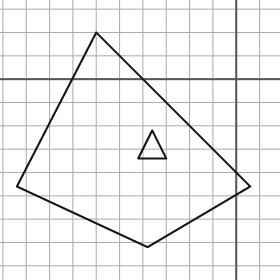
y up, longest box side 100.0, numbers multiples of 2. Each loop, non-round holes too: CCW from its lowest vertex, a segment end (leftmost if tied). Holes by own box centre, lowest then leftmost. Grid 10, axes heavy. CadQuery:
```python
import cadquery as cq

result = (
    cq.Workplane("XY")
    .moveTo(-38.0, -72.0)
    .lineTo(6.0, -46.0)
    .lineTo(-60.0, 20.0)
    .lineTo(-94.0, -46.0)
    .close()
    .moveTo(-42.0, -34.0)
    .lineTo(-30.0, -34.0)
    .lineTo(-36.0, -22.0)
    .close()
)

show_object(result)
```